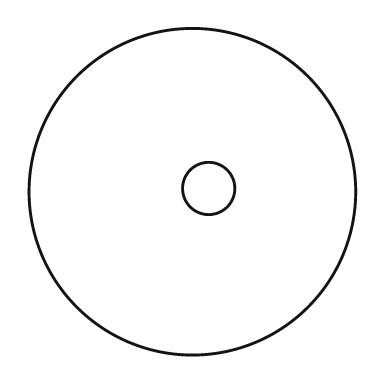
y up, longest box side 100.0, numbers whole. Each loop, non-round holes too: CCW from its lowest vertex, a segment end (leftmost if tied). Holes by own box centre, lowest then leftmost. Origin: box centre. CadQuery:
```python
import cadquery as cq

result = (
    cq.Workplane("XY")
    .moveTo(0.0, 0.0)
    .circle(50.0)
    .moveTo(5.0, 1.0)
    .circle(8.0)
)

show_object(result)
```